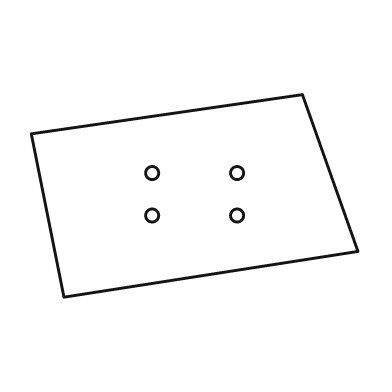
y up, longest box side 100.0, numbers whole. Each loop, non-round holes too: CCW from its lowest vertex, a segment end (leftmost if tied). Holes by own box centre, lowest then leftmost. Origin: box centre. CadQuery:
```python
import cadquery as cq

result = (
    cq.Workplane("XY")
    .moveTo(-40.0, -31.0)
    .lineTo(50.0, -17.0)
    .lineTo(33.0, 31.0)
    .lineTo(-50.0, 19.0)
    .close()
    .moveTo(-13.0, -6.0)
    .circle(2.0)
    .moveTo(13.0, -6.0)
    .circle(2.0)
    .moveTo(-13.0, 7.0)
    .circle(2.0)
    .moveTo(13.0, 7.0)
    .circle(2.0)
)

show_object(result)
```